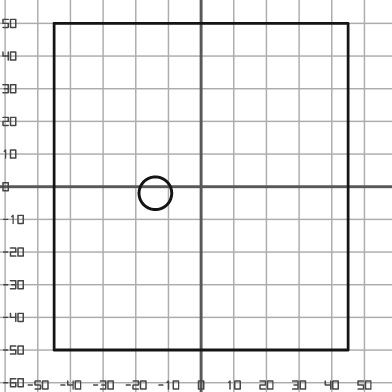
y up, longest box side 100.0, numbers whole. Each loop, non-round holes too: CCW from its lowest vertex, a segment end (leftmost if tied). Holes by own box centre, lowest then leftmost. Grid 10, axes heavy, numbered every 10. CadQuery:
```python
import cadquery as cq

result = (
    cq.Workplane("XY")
    .moveTo(-45.0, -50.0)
    .lineTo(45.0, -50.0)
    .lineTo(45.0, 50.0)
    .lineTo(-45.0, 50.0)
    .close()
    .moveTo(-14.0, -2.0)
    .circle(5.0)
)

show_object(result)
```